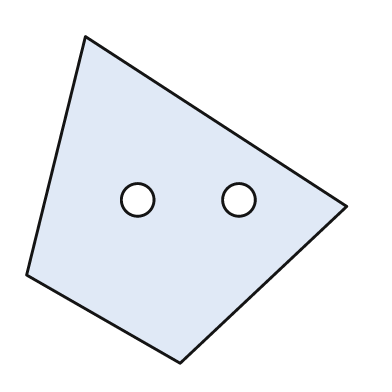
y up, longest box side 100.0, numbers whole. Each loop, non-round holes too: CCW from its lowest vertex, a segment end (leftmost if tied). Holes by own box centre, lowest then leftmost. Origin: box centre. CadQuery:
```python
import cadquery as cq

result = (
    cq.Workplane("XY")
    .moveTo(-2.0, -50.0)
    .lineTo(49.0, -2.0)
    .lineTo(-31.0, 50.0)
    .lineTo(-49.0, -23.0)
    .close()
    .moveTo(-15.0, 0.0)
    .circle(5.0)
    .moveTo(16.0, 0.0)
    .circle(5.0)
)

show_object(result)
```